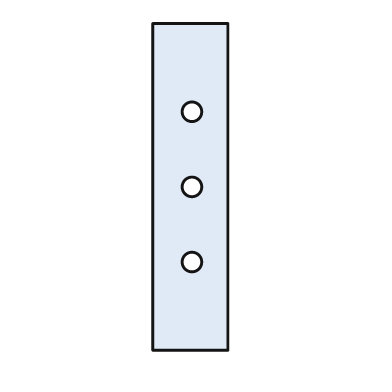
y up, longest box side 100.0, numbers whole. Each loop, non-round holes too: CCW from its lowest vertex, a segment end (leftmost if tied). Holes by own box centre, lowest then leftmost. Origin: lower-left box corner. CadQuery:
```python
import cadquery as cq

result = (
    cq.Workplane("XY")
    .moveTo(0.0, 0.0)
    .lineTo(23.0, 0.0)
    .lineTo(23.0, 100.0)
    .lineTo(0.0, 100.0)
    .close()
    .moveTo(12.0, 27.0)
    .circle(3.0)
    .moveTo(12.0, 50.0)
    .circle(3.0)
    .moveTo(12.0, 73.0)
    .circle(3.0)
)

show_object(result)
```